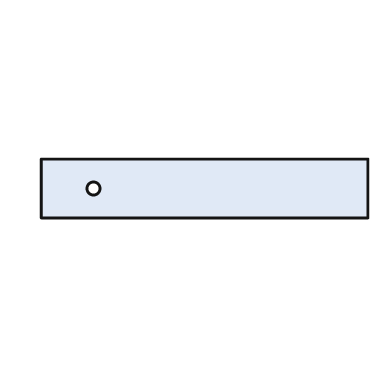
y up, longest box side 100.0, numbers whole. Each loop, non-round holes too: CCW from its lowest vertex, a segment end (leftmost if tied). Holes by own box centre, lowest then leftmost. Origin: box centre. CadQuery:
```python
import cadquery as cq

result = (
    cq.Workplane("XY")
    .moveTo(-50.0, -9.0)
    .lineTo(50.0, -9.0)
    .lineTo(50.0, 9.0)
    .lineTo(-50.0, 9.0)
    .close()
    .moveTo(-34.0, 0.0)
    .circle(2.0)
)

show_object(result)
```